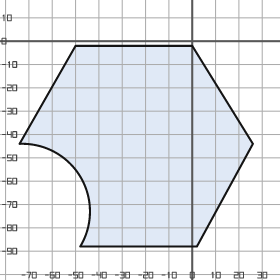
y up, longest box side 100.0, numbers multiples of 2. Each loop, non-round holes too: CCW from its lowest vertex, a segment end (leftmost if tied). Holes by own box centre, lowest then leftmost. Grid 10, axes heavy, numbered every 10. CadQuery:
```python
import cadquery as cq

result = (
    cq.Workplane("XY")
    .moveTo(-48.0, -88.0)
    .lineTo(2.0, -88.0)
    .lineTo(26.0, -44.0)
    .lineTo(0.0, -2.0)
    .lineTo(-50.0, -2.0)
    .lineTo(-74.0, -44.0)
    .threePointArc((-48.0, -58.0), (-48.0, -88.0))
    .close()
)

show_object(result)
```